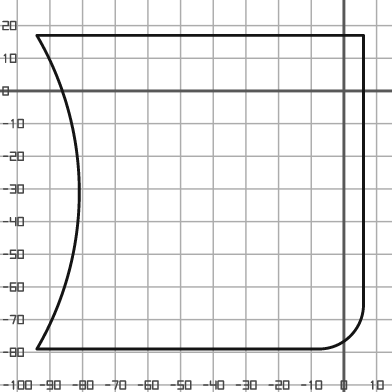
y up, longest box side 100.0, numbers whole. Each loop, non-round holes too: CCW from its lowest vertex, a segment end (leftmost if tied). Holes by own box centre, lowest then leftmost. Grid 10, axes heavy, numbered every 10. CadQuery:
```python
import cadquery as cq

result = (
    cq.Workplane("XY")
    .moveTo(-94.0, -79.0)
    .lineTo(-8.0, -79.0)
    .threePointArc((2.0, -75.0), (6.0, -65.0))
    .lineTo(6.0, 17.0)
    .lineTo(-94.0, 17.0)
    .threePointArc((-81.0, -31.0), (-94.0, -79.0))
    .close()
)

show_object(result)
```